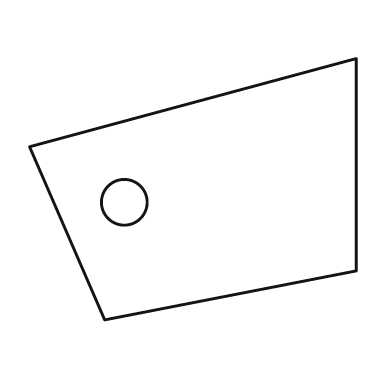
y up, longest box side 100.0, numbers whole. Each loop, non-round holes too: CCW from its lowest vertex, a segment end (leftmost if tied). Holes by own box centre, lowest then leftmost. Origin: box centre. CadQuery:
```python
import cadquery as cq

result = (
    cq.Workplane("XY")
    .moveTo(-27.0, -40.0)
    .lineTo(50.0, -25.0)
    .lineTo(50.0, 40.0)
    .lineTo(-50.0, 13.0)
    .close()
    .moveTo(-21.0, -4.0)
    .circle(7.0)
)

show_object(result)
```